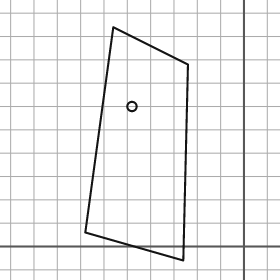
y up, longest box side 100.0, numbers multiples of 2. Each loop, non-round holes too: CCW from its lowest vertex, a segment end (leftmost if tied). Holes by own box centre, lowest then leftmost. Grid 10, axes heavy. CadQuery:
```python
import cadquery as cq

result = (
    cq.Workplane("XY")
    .moveTo(-26.0, -6.0)
    .lineTo(-24.0, 78.0)
    .lineTo(-56.0, 94.0)
    .lineTo(-68.0, 6.0)
    .close()
    .moveTo(-48.0, 60.0)
    .circle(2.0)
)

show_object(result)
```